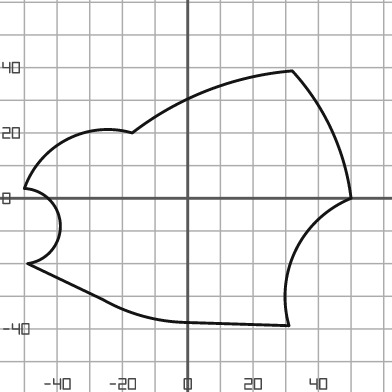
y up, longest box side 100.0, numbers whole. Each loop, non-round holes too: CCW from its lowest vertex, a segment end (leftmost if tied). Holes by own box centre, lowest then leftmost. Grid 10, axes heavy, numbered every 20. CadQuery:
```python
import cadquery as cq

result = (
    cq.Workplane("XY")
    .moveTo(31.0, -39.0)
    .threePointArc((33.0, -16.0), (50.0, 0.0))
    .threePointArc((44.0, 21.0), (32.0, 39.0))
    .threePointArc((6.0, 33.0), (-17.0, 20.0))
    .threePointArc((-37.0, 18.0), (-50.0, 3.0))
    .threePointArc((-39.0, -8.0), (-49.0, -20.0))
    .lineTo(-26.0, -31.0)
    .threePointArc((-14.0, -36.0), (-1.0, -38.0))
    .close()
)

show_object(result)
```